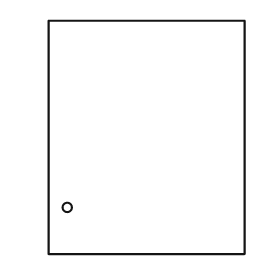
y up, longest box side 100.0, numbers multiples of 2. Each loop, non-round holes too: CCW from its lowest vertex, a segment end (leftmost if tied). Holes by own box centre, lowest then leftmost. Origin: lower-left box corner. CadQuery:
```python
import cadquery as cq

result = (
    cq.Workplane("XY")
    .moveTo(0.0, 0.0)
    .lineTo(84.0, 0.0)
    .lineTo(84.0, 100.0)
    .lineTo(0.0, 100.0)
    .close()
    .moveTo(8.0, 20.0)
    .circle(2.0)
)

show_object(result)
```